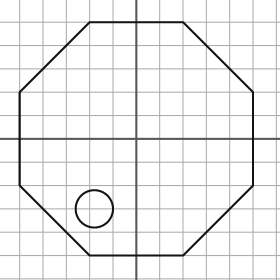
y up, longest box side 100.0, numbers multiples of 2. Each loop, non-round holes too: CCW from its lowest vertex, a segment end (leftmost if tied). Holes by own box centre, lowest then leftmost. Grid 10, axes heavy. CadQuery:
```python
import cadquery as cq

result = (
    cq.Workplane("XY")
    .moveTo(-20.0, -50.0)
    .lineTo(20.0, -50.0)
    .lineTo(50.0, -20.0)
    .lineTo(50.0, 20.0)
    .lineTo(20.0, 50.0)
    .lineTo(-20.0, 50.0)
    .lineTo(-50.0, 20.0)
    .lineTo(-50.0, -20.0)
    .close()
    .moveTo(-18.0, -30.0)
    .circle(8.0)
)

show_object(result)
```